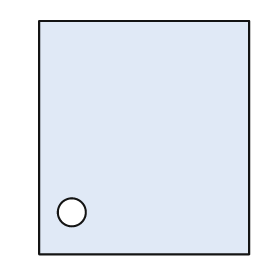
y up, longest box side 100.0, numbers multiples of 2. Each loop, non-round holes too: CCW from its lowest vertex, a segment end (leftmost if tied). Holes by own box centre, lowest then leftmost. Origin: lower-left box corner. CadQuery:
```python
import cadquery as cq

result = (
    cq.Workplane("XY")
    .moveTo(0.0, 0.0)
    .lineTo(90.0, 0.0)
    .lineTo(90.0, 100.0)
    .lineTo(0.0, 100.0)
    .close()
    .moveTo(14.0, 18.0)
    .circle(6.0)
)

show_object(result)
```